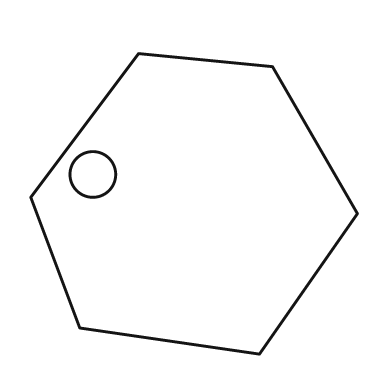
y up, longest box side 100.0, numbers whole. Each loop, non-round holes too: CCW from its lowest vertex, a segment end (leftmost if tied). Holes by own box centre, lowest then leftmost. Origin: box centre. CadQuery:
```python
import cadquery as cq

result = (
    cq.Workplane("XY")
    .moveTo(20.0, -46.0)
    .lineTo(50.0, -3.0)
    .lineTo(24.0, 42.0)
    .lineTo(-17.0, 46.0)
    .lineTo(-50.0, 2.0)
    .lineTo(-35.0, -38.0)
    .close()
    .moveTo(-31.0, 9.0)
    .circle(7.0)
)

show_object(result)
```